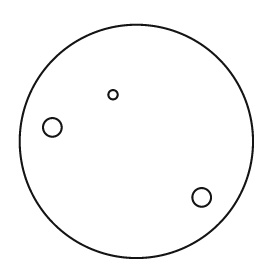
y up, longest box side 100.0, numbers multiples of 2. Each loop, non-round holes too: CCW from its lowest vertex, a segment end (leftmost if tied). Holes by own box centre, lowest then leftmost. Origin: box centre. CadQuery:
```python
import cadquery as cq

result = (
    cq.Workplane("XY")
    .moveTo(0.0, 0.0)
    .circle(50.0)
    .moveTo(28.0, -24.0)
    .circle(4.0)
    .moveTo(-36.0, 6.0)
    .circle(4.0)
    .moveTo(-10.0, 20.0)
    .circle(2.0)
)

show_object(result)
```